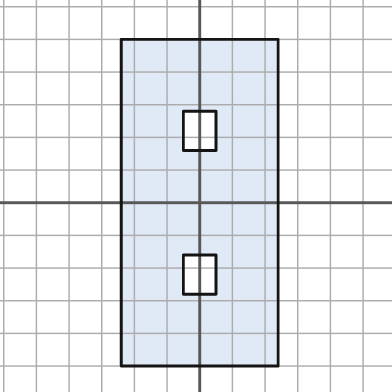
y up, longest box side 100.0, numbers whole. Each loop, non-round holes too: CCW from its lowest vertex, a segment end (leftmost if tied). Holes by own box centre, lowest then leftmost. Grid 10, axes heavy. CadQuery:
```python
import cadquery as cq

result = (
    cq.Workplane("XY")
    .moveTo(-24.0, -50.0)
    .lineTo(24.0, -50.0)
    .lineTo(24.0, 50.0)
    .lineTo(-24.0, 50.0)
    .close()
    .moveTo(-5.0, -28.0)
    .lineTo(5.0, -28.0)
    .lineTo(5.0, -16.0)
    .lineTo(-5.0, -16.0)
    .close()
    .moveTo(-5.0, 16.0)
    .lineTo(5.0, 16.0)
    .lineTo(5.0, 28.0)
    .lineTo(-5.0, 28.0)
    .close()
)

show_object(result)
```